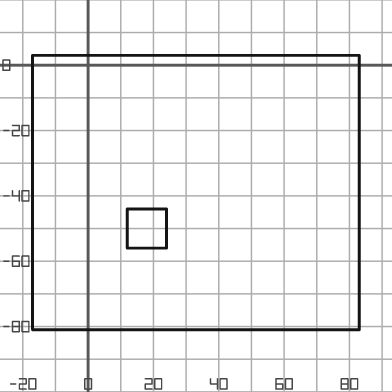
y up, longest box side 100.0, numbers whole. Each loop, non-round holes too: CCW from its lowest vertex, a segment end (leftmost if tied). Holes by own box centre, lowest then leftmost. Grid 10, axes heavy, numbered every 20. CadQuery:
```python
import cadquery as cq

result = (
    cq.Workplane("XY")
    .moveTo(-17.0, -81.0)
    .lineTo(83.0, -81.0)
    .lineTo(83.0, 3.0)
    .lineTo(-17.0, 3.0)
    .close()
    .moveTo(12.0, -56.0)
    .lineTo(24.0, -56.0)
    .lineTo(24.0, -44.0)
    .lineTo(12.0, -44.0)
    .close()
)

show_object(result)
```